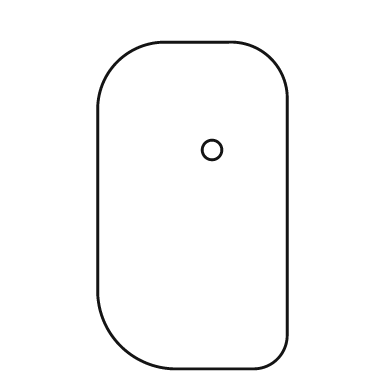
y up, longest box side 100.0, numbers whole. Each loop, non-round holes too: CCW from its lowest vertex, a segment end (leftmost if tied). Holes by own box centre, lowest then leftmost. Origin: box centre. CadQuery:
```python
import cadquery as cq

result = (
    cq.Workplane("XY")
    .moveTo(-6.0, -50.0)
    .lineTo(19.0, -50.0)
    .threePointArc((26.0, -47.0), (29.0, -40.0))
    .lineTo(29.0, 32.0)
    .threePointArc((24.0, 45.0), (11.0, 50.0))
    .lineTo(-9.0, 50.0)
    .threePointArc((-23.0, 44.0), (-29.0, 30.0))
    .lineTo(-29.0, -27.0)
    .threePointArc((-22.0, -43.0), (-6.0, -50.0))
    .close()
    .moveTo(6.0, 17.0)
    .circle(3.0)
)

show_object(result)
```